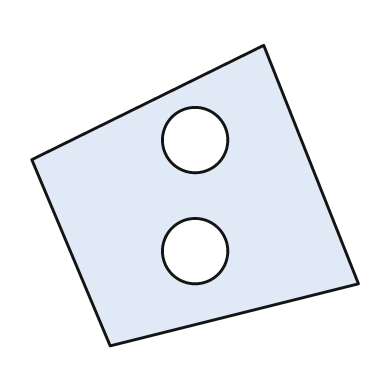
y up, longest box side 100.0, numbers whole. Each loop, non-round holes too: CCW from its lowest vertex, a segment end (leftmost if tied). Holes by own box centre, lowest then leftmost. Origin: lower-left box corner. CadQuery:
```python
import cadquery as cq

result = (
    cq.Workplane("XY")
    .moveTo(24.0, 0.0)
    .lineTo(100.0, 19.0)
    .lineTo(71.0, 92.0)
    .lineTo(0.0, 57.0)
    .close()
    .moveTo(50.0, 29.0)
    .circle(10.0)
    .moveTo(50.0, 63.0)
    .circle(10.0)
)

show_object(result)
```